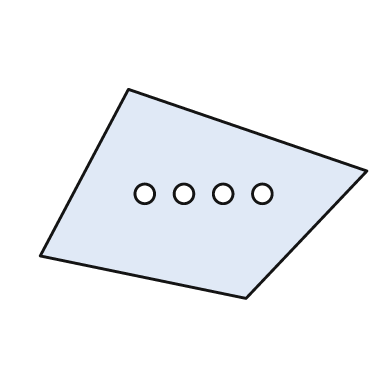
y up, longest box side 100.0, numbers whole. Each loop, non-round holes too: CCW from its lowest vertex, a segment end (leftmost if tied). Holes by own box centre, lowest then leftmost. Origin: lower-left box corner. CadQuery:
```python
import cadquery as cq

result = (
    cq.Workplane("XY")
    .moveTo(63.0, 0.0)
    .lineTo(100.0, 39.0)
    .lineTo(27.0, 64.0)
    .lineTo(0.0, 13.0)
    .close()
    .moveTo(32.0, 32.0)
    .circle(3.0)
    .moveTo(44.0, 32.0)
    .circle(3.0)
    .moveTo(56.0, 32.0)
    .circle(3.0)
    .moveTo(68.0, 32.0)
    .circle(3.0)
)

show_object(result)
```